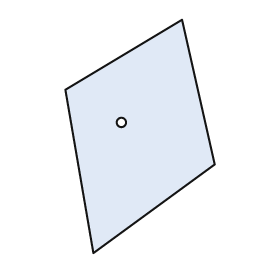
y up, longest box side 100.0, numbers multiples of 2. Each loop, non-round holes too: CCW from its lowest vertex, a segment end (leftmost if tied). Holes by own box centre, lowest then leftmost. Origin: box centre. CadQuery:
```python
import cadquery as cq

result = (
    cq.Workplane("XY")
    .moveTo(-20.0, -50.0)
    .lineTo(32.0, -12.0)
    .lineTo(18.0, 50.0)
    .lineTo(-32.0, 20.0)
    .close()
    .moveTo(-8.0, 6.0)
    .circle(2.0)
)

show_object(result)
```